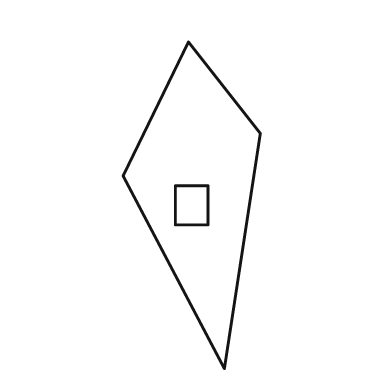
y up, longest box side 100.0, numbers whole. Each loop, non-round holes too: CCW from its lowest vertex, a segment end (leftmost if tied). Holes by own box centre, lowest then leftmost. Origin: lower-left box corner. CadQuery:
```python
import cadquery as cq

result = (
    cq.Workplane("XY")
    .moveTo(31.0, 0.0)
    .lineTo(42.0, 72.0)
    .lineTo(20.0, 100.0)
    .lineTo(0.0, 59.0)
    .close()
    .moveTo(16.0, 44.0)
    .lineTo(26.0, 44.0)
    .lineTo(26.0, 56.0)
    .lineTo(16.0, 56.0)
    .close()
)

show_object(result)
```